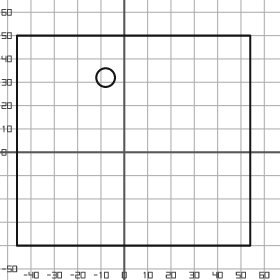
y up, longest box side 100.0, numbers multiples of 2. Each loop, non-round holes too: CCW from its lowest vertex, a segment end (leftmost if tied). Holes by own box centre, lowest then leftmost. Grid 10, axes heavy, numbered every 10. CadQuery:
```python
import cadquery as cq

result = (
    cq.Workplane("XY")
    .moveTo(-46.0, -40.0)
    .lineTo(54.0, -40.0)
    .lineTo(54.0, 50.0)
    .lineTo(-46.0, 50.0)
    .close()
    .moveTo(-8.0, 32.0)
    .circle(4.0)
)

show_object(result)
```